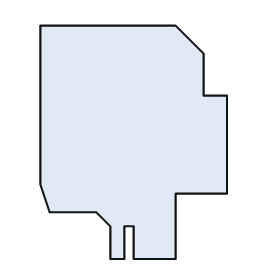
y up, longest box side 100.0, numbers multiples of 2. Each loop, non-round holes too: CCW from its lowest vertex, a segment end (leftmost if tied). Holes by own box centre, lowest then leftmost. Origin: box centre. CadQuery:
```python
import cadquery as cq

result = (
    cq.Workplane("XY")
    .moveTo(-10.0, -50.0)
    .lineTo(-4.0, -50.0)
    .lineTo(-4.0, -36.0)
    .lineTo(0.0, -36.0)
    .lineTo(0.0, -50.0)
    .lineTo(18.0, -50.0)
    .lineTo(18.0, -22.0)
    .lineTo(40.0, -22.0)
    .lineTo(40.0, 20.0)
    .lineTo(30.0, 20.0)
    .lineTo(30.0, 38.0)
    .lineTo(18.0, 50.0)
    .lineTo(-40.0, 50.0)
    .lineTo(-40.0, -18.0)
    .lineTo(-36.0, -30.0)
    .lineTo(-16.0, -30.0)
    .lineTo(-10.0, -36.0)
    .close()
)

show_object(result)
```